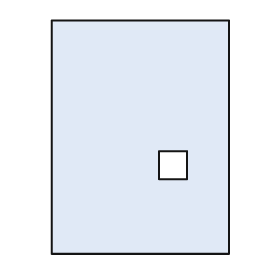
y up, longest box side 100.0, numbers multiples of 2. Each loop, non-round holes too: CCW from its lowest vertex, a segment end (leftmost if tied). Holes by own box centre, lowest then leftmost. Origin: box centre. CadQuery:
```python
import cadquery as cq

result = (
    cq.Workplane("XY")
    .moveTo(-38.0, -50.0)
    .lineTo(38.0, -50.0)
    .lineTo(38.0, 50.0)
    .lineTo(-38.0, 50.0)
    .close()
    .moveTo(8.0, -18.0)
    .lineTo(20.0, -18.0)
    .lineTo(20.0, -6.0)
    .lineTo(8.0, -6.0)
    .close()
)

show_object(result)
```